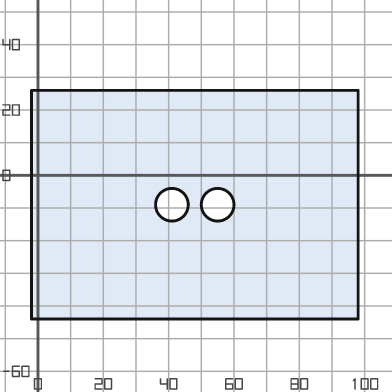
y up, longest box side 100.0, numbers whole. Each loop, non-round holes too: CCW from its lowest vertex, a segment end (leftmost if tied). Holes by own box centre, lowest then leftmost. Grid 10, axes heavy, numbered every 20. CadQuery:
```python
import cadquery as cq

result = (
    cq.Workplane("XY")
    .moveTo(-2.0, -44.0)
    .lineTo(98.0, -44.0)
    .lineTo(98.0, 26.0)
    .lineTo(-2.0, 26.0)
    .close()
    .moveTo(41.0, -9.0)
    .circle(5.0)
    .moveTo(55.0, -9.0)
    .circle(5.0)
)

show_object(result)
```